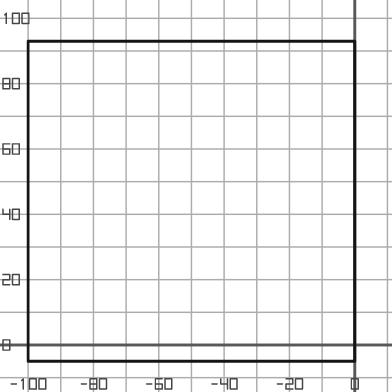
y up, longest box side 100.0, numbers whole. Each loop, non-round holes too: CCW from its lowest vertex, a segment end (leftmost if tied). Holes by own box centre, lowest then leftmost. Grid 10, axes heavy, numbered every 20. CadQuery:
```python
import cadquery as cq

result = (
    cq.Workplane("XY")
    .moveTo(-100.0, -5.0)
    .lineTo(0.0, -5.0)
    .lineTo(0.0, 93.0)
    .lineTo(-100.0, 93.0)
    .close()
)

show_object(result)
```